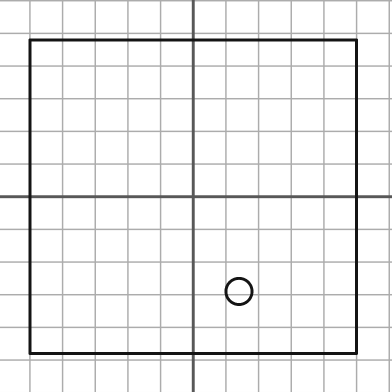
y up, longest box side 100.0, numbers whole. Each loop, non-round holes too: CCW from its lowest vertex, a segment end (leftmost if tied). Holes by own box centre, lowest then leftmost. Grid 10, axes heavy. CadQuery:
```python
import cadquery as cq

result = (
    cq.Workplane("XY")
    .moveTo(-50.0, -48.0)
    .lineTo(50.0, -48.0)
    .lineTo(50.0, 48.0)
    .lineTo(-50.0, 48.0)
    .close()
    .moveTo(14.0, -29.0)
    .circle(4.0)
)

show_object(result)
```